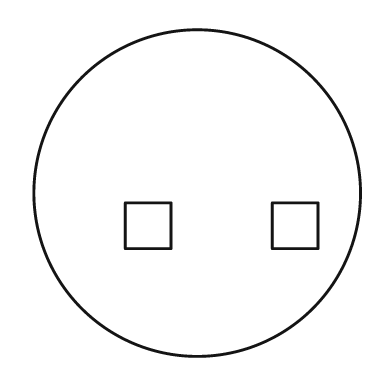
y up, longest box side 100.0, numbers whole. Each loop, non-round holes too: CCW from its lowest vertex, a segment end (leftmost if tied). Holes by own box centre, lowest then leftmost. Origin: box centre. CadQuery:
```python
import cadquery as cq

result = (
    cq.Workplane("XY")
    .moveTo(0.0, 0.0)
    .circle(50.0)
    .moveTo(-22.0, -17.0)
    .lineTo(-8.0, -17.0)
    .lineTo(-8.0, -3.0)
    .lineTo(-22.0, -3.0)
    .close()
    .moveTo(23.0, -17.0)
    .lineTo(37.0, -17.0)
    .lineTo(37.0, -3.0)
    .lineTo(23.0, -3.0)
    .close()
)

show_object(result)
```